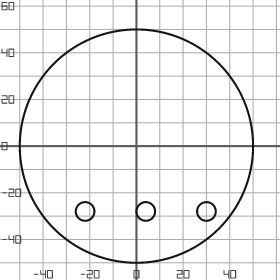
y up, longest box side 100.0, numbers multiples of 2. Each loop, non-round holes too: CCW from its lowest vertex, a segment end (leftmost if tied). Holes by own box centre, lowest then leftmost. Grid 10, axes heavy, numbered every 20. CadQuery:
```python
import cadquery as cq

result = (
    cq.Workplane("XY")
    .moveTo(0.0, 0.0)
    .circle(50.0)
    .moveTo(-22.0, -28.0)
    .circle(4.0)
    .moveTo(4.0, -28.0)
    .circle(4.0)
    .moveTo(30.0, -28.0)
    .circle(4.0)
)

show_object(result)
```